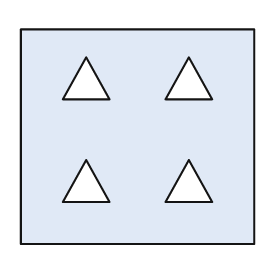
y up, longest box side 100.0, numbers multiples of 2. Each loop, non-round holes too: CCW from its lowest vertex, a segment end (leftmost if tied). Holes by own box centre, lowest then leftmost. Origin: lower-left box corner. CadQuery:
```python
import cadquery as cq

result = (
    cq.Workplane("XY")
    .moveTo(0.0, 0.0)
    .lineTo(100.0, 0.0)
    .lineTo(100.0, 92.0)
    .lineTo(0.0, 92.0)
    .close()
    .moveTo(18.0, 18.0)
    .lineTo(38.0, 18.0)
    .lineTo(28.0, 36.0)
    .close()
    .moveTo(62.0, 18.0)
    .lineTo(82.0, 18.0)
    .lineTo(72.0, 36.0)
    .close()
    .moveTo(18.0, 62.0)
    .lineTo(38.0, 62.0)
    .lineTo(28.0, 80.0)
    .close()
    .moveTo(62.0, 62.0)
    .lineTo(82.0, 62.0)
    .lineTo(72.0, 80.0)
    .close()
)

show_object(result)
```